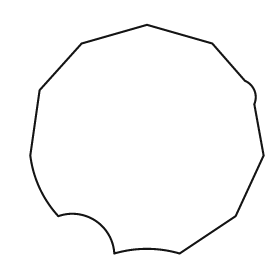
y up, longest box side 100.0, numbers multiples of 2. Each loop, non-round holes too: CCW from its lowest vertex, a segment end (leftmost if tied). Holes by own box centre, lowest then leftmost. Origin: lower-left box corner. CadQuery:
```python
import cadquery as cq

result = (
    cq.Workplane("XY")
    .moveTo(36.0, 0.0)
    .threePointArc((50.0, 2.0), (64.0, 0.0))
    .lineTo(88.0, 16.0)
    .lineTo(100.0, 42.0)
    .lineTo(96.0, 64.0)
    .threePointArc((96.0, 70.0), (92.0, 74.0))
    .lineTo(78.0, 90.0)
    .lineTo(50.0, 98.0)
    .lineTo(22.0, 90.0)
    .lineTo(4.0, 70.0)
    .lineTo(0.0, 42.0)
    .threePointArc((4.0, 28.0), (12.0, 16.0))
    .threePointArc((28.0, 14.0), (36.0, 0.0))
    .close()
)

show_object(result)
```